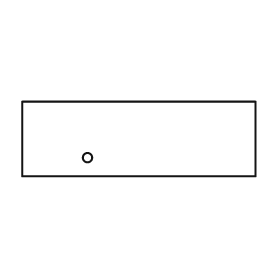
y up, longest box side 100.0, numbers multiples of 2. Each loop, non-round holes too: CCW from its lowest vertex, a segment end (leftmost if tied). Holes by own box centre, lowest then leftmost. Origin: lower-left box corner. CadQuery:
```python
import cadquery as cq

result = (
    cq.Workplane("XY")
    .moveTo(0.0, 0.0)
    .lineTo(100.0, 0.0)
    .lineTo(100.0, 32.0)
    .lineTo(0.0, 32.0)
    .close()
    .moveTo(28.0, 8.0)
    .circle(2.0)
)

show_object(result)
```